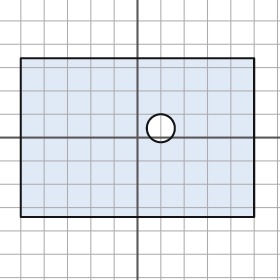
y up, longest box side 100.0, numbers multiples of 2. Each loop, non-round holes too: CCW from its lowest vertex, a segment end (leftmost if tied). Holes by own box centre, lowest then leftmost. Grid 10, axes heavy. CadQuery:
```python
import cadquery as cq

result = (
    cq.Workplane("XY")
    .moveTo(-50.0, -34.0)
    .lineTo(50.0, -34.0)
    .lineTo(50.0, 34.0)
    .lineTo(-50.0, 34.0)
    .close()
    .moveTo(10.0, 4.0)
    .circle(6.0)
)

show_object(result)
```